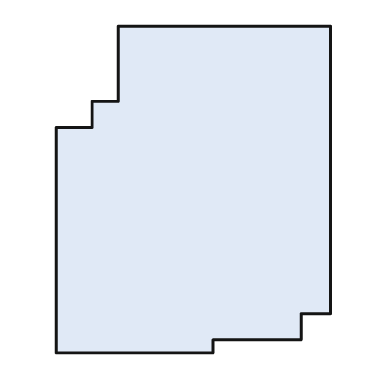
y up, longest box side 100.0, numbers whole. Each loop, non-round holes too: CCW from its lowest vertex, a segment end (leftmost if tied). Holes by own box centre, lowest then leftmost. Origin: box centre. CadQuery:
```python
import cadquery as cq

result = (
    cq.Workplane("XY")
    .moveTo(-42.0, -50.0)
    .lineTo(6.0, -50.0)
    .lineTo(6.0, -46.0)
    .lineTo(33.0, -46.0)
    .lineTo(33.0, -38.0)
    .lineTo(42.0, -38.0)
    .lineTo(42.0, 50.0)
    .lineTo(-23.0, 50.0)
    .lineTo(-23.0, 27.0)
    .lineTo(-31.0, 27.0)
    .lineTo(-31.0, 19.0)
    .lineTo(-42.0, 19.0)
    .close()
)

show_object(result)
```